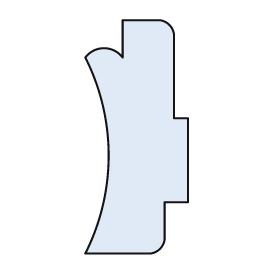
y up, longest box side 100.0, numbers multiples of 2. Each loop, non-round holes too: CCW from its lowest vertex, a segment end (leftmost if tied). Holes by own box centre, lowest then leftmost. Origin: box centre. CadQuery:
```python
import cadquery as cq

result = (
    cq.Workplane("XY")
    .moveTo(-22.0, -50.0)
    .lineTo(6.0, -50.0)
    .threePointArc((10.0, -48.0), (12.0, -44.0))
    .lineTo(12.0, -28.0)
    .lineTo(22.0, -28.0)
    .lineTo(22.0, 8.0)
    .lineTo(16.0, 8.0)
    .lineTo(16.0, 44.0)
    .threePointArc((14.0, 48.0), (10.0, 50.0))
    .lineTo(-6.0, 50.0)
    .lineTo(-6.0, 34.0)
    .threePointArc((-14.0, 38.0), (-22.0, 34.0))
    .threePointArc((-12.0, -8.0), (-22.0, -50.0))
    .close()
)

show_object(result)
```